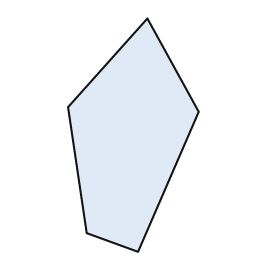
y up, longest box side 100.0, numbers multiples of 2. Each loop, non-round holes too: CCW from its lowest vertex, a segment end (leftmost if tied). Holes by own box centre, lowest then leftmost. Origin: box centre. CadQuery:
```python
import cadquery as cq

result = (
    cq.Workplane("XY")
    .moveTo(2.0, -50.0)
    .lineTo(28.0, 10.0)
    .lineTo(6.0, 50.0)
    .lineTo(-28.0, 12.0)
    .lineTo(-20.0, -42.0)
    .close()
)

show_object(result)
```